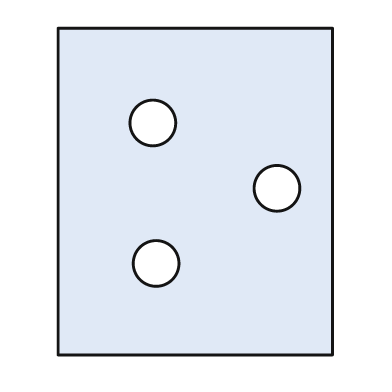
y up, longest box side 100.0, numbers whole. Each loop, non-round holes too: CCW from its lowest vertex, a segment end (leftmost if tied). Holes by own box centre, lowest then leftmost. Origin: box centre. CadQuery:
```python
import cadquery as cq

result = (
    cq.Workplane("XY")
    .moveTo(-42.0, -50.0)
    .lineTo(42.0, -50.0)
    .lineTo(42.0, 50.0)
    .lineTo(-42.0, 50.0)
    .close()
    .moveTo(-12.0, -22.0)
    .circle(7.0)
    .moveTo(25.0, 1.0)
    .circle(7.0)
    .moveTo(-13.0, 21.0)
    .circle(7.0)
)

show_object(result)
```